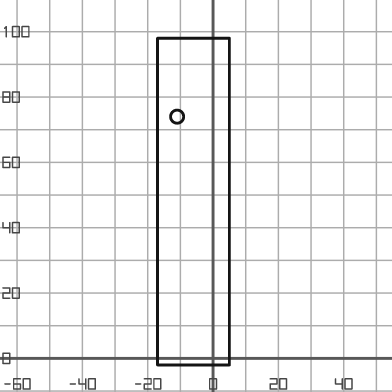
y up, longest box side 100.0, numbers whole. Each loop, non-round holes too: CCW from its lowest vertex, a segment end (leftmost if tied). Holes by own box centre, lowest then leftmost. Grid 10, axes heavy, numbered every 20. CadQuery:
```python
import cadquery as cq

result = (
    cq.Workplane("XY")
    .moveTo(-17.0, -2.0)
    .lineTo(5.0, -2.0)
    .lineTo(5.0, 98.0)
    .lineTo(-17.0, 98.0)
    .close()
    .moveTo(-11.0, 74.0)
    .circle(2.0)
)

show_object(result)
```